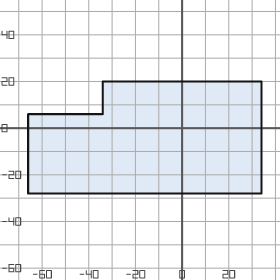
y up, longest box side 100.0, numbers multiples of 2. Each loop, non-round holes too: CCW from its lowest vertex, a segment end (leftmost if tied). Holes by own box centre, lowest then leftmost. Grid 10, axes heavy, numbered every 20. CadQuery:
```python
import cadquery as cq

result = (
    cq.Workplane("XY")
    .moveTo(-66.0, -28.0)
    .lineTo(34.0, -28.0)
    .lineTo(34.0, 20.0)
    .lineTo(-34.0, 20.0)
    .lineTo(-34.0, 6.0)
    .lineTo(-66.0, 6.0)
    .close()
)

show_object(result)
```